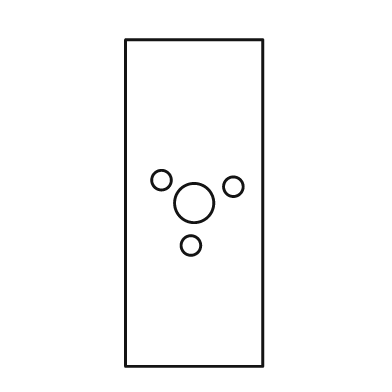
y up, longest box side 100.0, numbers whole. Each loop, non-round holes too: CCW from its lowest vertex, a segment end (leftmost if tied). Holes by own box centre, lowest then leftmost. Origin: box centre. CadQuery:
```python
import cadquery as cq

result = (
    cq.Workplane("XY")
    .moveTo(-21.0, -50.0)
    .lineTo(21.0, -50.0)
    .lineTo(21.0, 50.0)
    .lineTo(-21.0, 50.0)
    .close()
    .moveTo(-1.0, -13.0)
    .circle(3.0)
    .moveTo(0.0, 0.0)
    .circle(6.0)
    .moveTo(12.0, 5.0)
    .circle(3.0)
    .moveTo(-10.0, 7.0)
    .circle(3.0)
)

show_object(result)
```